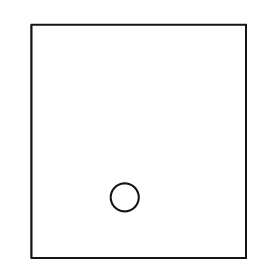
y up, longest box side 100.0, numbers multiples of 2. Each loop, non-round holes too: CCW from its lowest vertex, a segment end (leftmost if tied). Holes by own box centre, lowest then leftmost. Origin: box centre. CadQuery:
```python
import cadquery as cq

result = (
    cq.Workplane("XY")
    .moveTo(-46.0, -50.0)
    .lineTo(46.0, -50.0)
    .lineTo(46.0, 50.0)
    .lineTo(-46.0, 50.0)
    .close()
    .moveTo(-6.0, -24.0)
    .circle(6.0)
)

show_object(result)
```